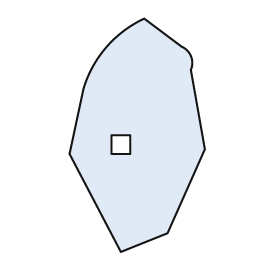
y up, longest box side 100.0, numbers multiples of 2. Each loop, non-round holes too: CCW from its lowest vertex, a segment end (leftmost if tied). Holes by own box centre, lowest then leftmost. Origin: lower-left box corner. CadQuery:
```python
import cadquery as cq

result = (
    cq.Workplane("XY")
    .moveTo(22.0, 0.0)
    .lineTo(42.0, 8.0)
    .lineTo(58.0, 44.0)
    .lineTo(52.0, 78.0)
    .threePointArc((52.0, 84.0), (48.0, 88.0))
    .lineTo(32.0, 100.0)
    .threePointArc((16.0, 88.0), (6.0, 70.0))
    .lineTo(0.0, 42.0)
    .close()
    .moveTo(18.0, 42.0)
    .lineTo(26.0, 42.0)
    .lineTo(26.0, 50.0)
    .lineTo(18.0, 50.0)
    .close()
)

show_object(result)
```